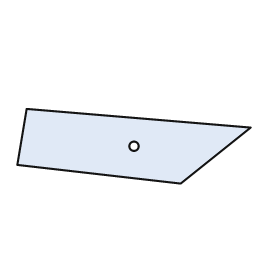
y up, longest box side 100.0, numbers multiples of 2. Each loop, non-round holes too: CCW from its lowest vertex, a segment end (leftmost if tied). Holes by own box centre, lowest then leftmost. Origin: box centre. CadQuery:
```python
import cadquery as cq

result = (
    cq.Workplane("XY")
    .moveTo(20.0, -16.0)
    .lineTo(50.0, 8.0)
    .lineTo(-46.0, 16.0)
    .lineTo(-50.0, -8.0)
    .close()
    .moveTo(0.0, 0.0)
    .circle(2.0)
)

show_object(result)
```